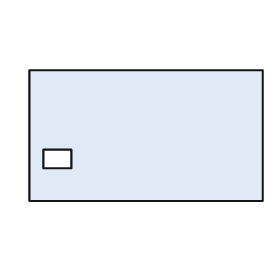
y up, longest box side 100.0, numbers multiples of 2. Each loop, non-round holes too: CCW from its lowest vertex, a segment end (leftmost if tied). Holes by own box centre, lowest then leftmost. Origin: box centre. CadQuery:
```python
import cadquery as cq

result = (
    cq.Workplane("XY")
    .moveTo(-50.0, -28.0)
    .lineTo(50.0, -28.0)
    .lineTo(50.0, 28.0)
    .lineTo(-50.0, 28.0)
    .close()
    .moveTo(-44.0, -14.0)
    .lineTo(-32.0, -14.0)
    .lineTo(-32.0, -6.0)
    .lineTo(-44.0, -6.0)
    .close()
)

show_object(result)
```